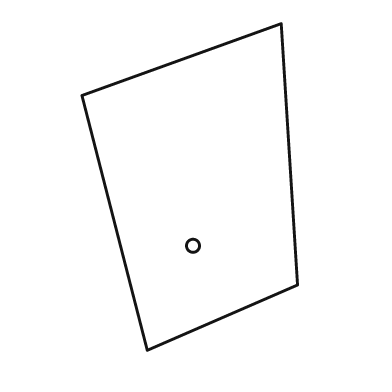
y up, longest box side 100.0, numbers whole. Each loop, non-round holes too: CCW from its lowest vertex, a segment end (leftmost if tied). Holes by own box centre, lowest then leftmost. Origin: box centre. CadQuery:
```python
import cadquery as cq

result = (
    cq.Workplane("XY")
    .moveTo(-13.0, -50.0)
    .lineTo(33.0, -30.0)
    .lineTo(28.0, 50.0)
    .lineTo(-33.0, 28.0)
    .close()
    .moveTo(1.0, -18.0)
    .circle(2.0)
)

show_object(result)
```